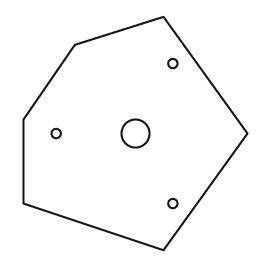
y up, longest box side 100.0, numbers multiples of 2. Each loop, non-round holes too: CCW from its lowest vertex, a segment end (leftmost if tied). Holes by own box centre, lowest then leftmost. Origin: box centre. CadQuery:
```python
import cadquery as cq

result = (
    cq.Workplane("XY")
    .moveTo(12.0, -50.0)
    .lineTo(48.0, 0.0)
    .lineTo(12.0, 50.0)
    .lineTo(-26.0, 38.0)
    .lineTo(-48.0, 6.0)
    .lineTo(-48.0, -30.0)
    .close()
    .moveTo(16.0, -30.0)
    .circle(2.0)
    .moveTo(-34.0, 0.0)
    .circle(2.0)
    .moveTo(0.0, 0.0)
    .circle(6.0)
    .moveTo(16.0, 30.0)
    .circle(2.0)
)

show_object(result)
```